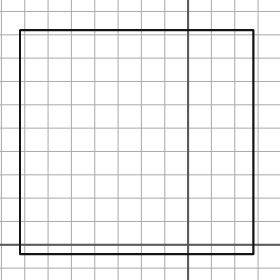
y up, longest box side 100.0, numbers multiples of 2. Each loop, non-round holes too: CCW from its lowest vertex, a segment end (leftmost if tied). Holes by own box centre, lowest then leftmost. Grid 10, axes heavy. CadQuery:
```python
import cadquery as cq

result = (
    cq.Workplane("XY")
    .moveTo(-72.0, -4.0)
    .lineTo(28.0, -4.0)
    .lineTo(28.0, 92.0)
    .lineTo(-72.0, 92.0)
    .close()
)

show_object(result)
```